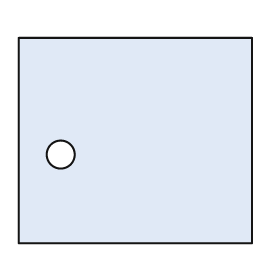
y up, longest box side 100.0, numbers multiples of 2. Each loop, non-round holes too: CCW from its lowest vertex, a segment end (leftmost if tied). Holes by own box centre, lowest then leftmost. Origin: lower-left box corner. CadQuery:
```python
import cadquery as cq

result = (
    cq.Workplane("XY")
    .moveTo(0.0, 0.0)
    .lineTo(100.0, 0.0)
    .lineTo(100.0, 88.0)
    .lineTo(0.0, 88.0)
    .close()
    .moveTo(18.0, 38.0)
    .circle(6.0)
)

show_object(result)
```